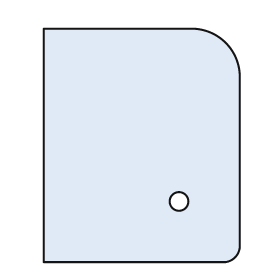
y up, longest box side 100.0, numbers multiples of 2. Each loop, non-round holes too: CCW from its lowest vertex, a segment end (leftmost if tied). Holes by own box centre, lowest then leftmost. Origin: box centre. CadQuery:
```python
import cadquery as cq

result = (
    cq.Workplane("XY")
    .moveTo(-42.0, -50.0)
    .lineTo(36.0, -50.0)
    .threePointArc((40.0, -48.0), (42.0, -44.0))
    .lineTo(42.0, 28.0)
    .threePointArc((36.0, 44.0), (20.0, 50.0))
    .lineTo(-42.0, 50.0)
    .close()
    .moveTo(16.0, -24.0)
    .circle(4.0)
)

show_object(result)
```